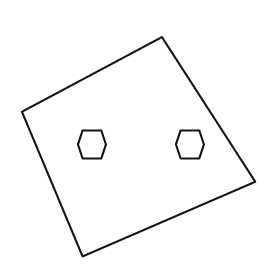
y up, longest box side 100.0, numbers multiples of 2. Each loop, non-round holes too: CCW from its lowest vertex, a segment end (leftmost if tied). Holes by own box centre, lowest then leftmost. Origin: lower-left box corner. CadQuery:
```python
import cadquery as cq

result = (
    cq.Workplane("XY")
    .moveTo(26.0, 0.0)
    .lineTo(100.0, 32.0)
    .lineTo(60.0, 94.0)
    .lineTo(0.0, 62.0)
    .close()
    .moveTo(26.0, 42.0)
    .lineTo(34.0, 42.0)
    .lineTo(36.0, 48.0)
    .lineTo(34.0, 54.0)
    .lineTo(26.0, 54.0)
    .lineTo(24.0, 48.0)
    .close()
    .moveTo(68.0, 42.0)
    .lineTo(76.0, 42.0)
    .lineTo(78.0, 48.0)
    .lineTo(76.0, 54.0)
    .lineTo(68.0, 54.0)
    .lineTo(66.0, 48.0)
    .close()
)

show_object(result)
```